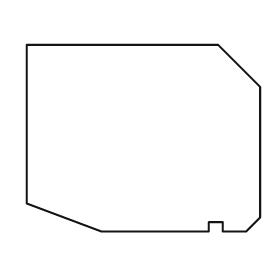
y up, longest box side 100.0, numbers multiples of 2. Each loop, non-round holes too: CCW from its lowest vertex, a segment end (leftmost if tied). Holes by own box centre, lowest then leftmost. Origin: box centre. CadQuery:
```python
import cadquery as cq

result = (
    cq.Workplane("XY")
    .moveTo(-18.0, -40.0)
    .lineTo(28.0, -40.0)
    .lineTo(28.0, -36.0)
    .lineTo(34.0, -36.0)
    .lineTo(34.0, -40.0)
    .lineTo(44.0, -40.0)
    .lineTo(50.0, -34.0)
    .lineTo(50.0, 22.0)
    .lineTo(32.0, 40.0)
    .lineTo(-50.0, 40.0)
    .lineTo(-50.0, -28.0)
    .close()
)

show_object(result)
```